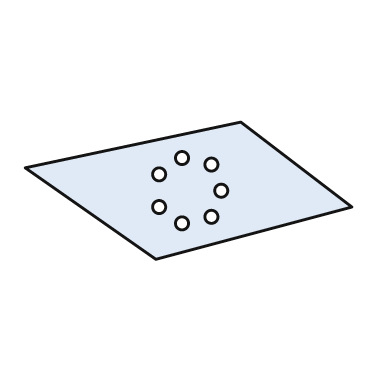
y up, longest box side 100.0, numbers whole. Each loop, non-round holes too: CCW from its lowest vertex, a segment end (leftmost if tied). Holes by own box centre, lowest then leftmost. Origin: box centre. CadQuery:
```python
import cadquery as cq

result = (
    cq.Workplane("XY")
    .moveTo(-10.0, -21.0)
    .lineTo(50.0, -5.0)
    .lineTo(16.0, 21.0)
    .lineTo(-50.0, 7.0)
    .close()
    .moveTo(-2.0, -10.0)
    .circle(2.0)
    .moveTo(7.0, -8.0)
    .circle(2.0)
    .moveTo(-9.0, -5.0)
    .circle(2.0)
    .moveTo(10.0, 0.0)
    .circle(2.0)
    .moveTo(-9.0, 5.0)
    .circle(2.0)
    .moveTo(7.0, 8.0)
    .circle(2.0)
    .moveTo(-2.0, 10.0)
    .circle(2.0)
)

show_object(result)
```